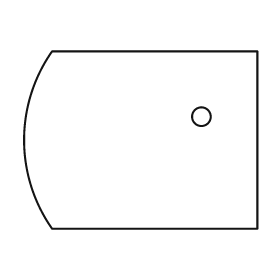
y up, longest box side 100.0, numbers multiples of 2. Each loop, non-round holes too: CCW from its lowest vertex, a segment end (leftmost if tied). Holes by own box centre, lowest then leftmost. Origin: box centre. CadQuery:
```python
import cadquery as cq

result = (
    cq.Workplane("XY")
    .moveTo(-38.0, -38.0)
    .lineTo(50.0, -38.0)
    .lineTo(50.0, 38.0)
    .lineTo(-38.0, 38.0)
    .threePointArc((-50.0, 0.0), (-38.0, -38.0))
    .close()
    .moveTo(26.0, 10.0)
    .circle(4.0)
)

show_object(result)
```